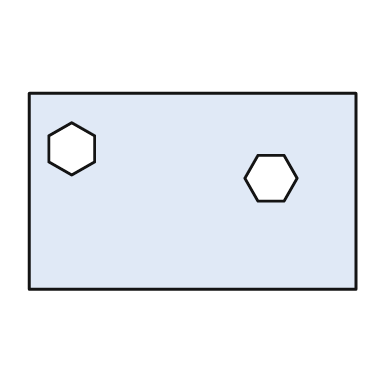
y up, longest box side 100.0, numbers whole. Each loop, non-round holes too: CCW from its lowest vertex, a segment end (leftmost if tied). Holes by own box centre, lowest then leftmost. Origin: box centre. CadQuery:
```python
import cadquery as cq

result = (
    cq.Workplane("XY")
    .moveTo(-50.0, -30.0)
    .lineTo(50.0, -30.0)
    .lineTo(50.0, 30.0)
    .lineTo(-50.0, 30.0)
    .close()
    .moveTo(20.0, -3.0)
    .lineTo(28.0, -3.0)
    .lineTo(32.0, 4.0)
    .lineTo(28.0, 11.0)
    .lineTo(20.0, 11.0)
    .lineTo(16.0, 4.0)
    .close()
    .moveTo(-37.0, 5.0)
    .lineTo(-30.0, 9.0)
    .lineTo(-30.0, 17.0)
    .lineTo(-37.0, 21.0)
    .lineTo(-44.0, 17.0)
    .lineTo(-44.0, 9.0)
    .close()
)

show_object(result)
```